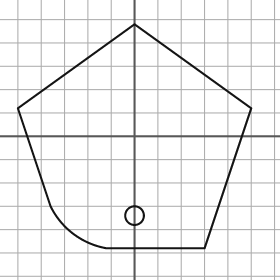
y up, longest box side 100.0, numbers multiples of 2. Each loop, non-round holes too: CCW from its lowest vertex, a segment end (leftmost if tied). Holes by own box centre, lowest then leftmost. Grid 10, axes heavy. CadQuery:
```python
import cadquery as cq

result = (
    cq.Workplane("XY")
    .moveTo(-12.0, -48.0)
    .lineTo(30.0, -48.0)
    .lineTo(50.0, 12.0)
    .lineTo(0.0, 48.0)
    .lineTo(-50.0, 12.0)
    .lineTo(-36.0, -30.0)
    .threePointArc((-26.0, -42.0), (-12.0, -48.0))
    .close()
    .moveTo(0.0, -34.0)
    .circle(4.0)
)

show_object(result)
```